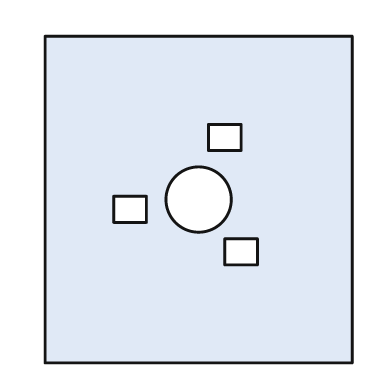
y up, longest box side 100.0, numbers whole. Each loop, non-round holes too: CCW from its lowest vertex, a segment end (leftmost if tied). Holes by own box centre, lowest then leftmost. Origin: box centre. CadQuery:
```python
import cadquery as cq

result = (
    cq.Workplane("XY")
    .moveTo(-47.0, -50.0)
    .lineTo(47.0, -50.0)
    .lineTo(47.0, 50.0)
    .lineTo(-47.0, 50.0)
    .close()
    .moveTo(8.0, -20.0)
    .lineTo(18.0, -20.0)
    .lineTo(18.0, -12.0)
    .lineTo(8.0, -12.0)
    .close()
    .moveTo(-26.0, -7.0)
    .lineTo(-16.0, -7.0)
    .lineTo(-16.0, 1.0)
    .lineTo(-26.0, 1.0)
    .close()
    .moveTo(0.0, 0.0)
    .circle(10.0)
    .moveTo(3.0, 15.0)
    .lineTo(13.0, 15.0)
    .lineTo(13.0, 23.0)
    .lineTo(3.0, 23.0)
    .close()
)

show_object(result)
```